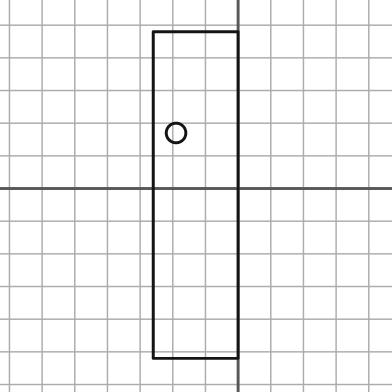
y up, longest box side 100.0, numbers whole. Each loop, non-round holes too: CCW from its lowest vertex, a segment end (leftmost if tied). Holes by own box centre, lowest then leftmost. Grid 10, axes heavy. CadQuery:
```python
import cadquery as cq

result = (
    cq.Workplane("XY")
    .moveTo(-26.0, -52.0)
    .lineTo(0.0, -52.0)
    .lineTo(0.0, 48.0)
    .lineTo(-26.0, 48.0)
    .close()
    .moveTo(-19.0, 17.0)
    .circle(3.0)
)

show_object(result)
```